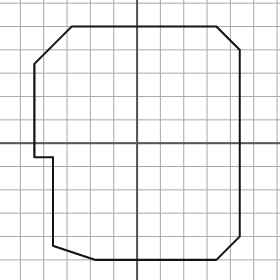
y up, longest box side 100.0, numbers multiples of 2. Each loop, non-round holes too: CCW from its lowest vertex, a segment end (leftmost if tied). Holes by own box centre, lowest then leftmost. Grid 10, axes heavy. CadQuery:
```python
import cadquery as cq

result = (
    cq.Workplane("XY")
    .moveTo(-18.0, -50.0)
    .lineTo(34.0, -50.0)
    .lineTo(44.0, -40.0)
    .lineTo(44.0, 40.0)
    .lineTo(34.0, 50.0)
    .lineTo(-28.0, 50.0)
    .lineTo(-44.0, 34.0)
    .lineTo(-44.0, -6.0)
    .lineTo(-36.0, -6.0)
    .lineTo(-36.0, -44.0)
    .close()
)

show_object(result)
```